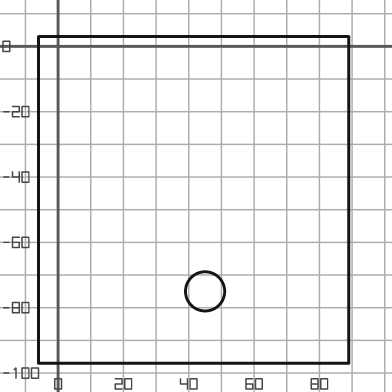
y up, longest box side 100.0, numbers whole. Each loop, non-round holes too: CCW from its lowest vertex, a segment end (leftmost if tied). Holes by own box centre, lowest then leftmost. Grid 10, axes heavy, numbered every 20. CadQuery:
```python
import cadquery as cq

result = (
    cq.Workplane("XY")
    .moveTo(-6.0, -97.0)
    .lineTo(89.0, -97.0)
    .lineTo(89.0, 3.0)
    .lineTo(-6.0, 3.0)
    .close()
    .moveTo(45.0, -75.0)
    .circle(6.0)
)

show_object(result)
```